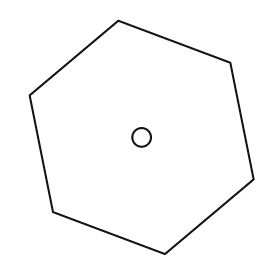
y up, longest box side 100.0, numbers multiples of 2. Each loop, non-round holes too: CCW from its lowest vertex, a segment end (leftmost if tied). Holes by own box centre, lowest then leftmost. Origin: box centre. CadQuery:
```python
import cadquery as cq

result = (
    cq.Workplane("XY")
    .moveTo(10.0, -50.0)
    .lineTo(48.0, -18.0)
    .lineTo(38.0, 32.0)
    .lineTo(-10.0, 50.0)
    .lineTo(-48.0, 18.0)
    .lineTo(-38.0, -32.0)
    .close()
    .moveTo(0.0, 0.0)
    .circle(4.0)
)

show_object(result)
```